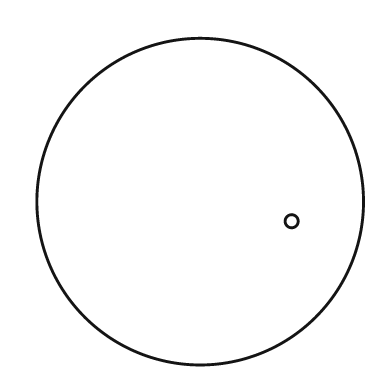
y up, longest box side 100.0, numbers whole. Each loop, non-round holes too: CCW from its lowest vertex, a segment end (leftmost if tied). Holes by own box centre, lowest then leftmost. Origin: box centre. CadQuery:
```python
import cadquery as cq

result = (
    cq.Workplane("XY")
    .moveTo(0.0, 0.0)
    .circle(50.0)
    .moveTo(28.0, -6.0)
    .circle(2.0)
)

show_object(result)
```